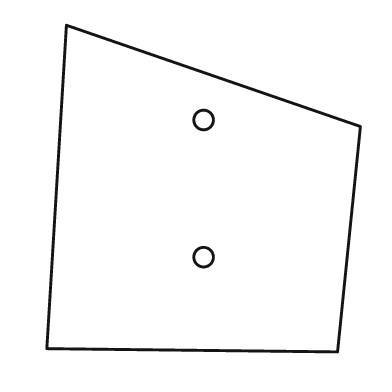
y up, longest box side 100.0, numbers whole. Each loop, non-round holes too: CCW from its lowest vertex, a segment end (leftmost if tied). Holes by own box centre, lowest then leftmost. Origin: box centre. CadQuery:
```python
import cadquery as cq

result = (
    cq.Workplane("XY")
    .moveTo(41.0, -50.0)
    .lineTo(48.0, 19.0)
    .lineTo(-42.0, 50.0)
    .lineTo(-48.0, -49.0)
    .close()
    .moveTo(0.0, -21.0)
    .circle(3.0)
    .moveTo(0.0, 21.0)
    .circle(3.0)
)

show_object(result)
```